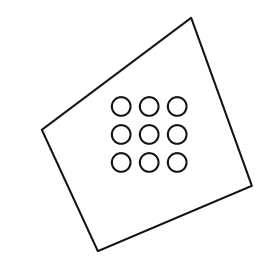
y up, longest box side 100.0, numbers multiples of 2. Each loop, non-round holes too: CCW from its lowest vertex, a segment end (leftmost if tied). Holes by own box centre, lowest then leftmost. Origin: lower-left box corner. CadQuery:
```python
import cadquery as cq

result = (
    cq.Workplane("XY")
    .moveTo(24.0, 0.0)
    .lineTo(90.0, 28.0)
    .lineTo(64.0, 100.0)
    .lineTo(0.0, 52.0)
    .close()
    .moveTo(34.0, 38.0)
    .circle(4.0)
    .moveTo(46.0, 38.0)
    .circle(4.0)
    .moveTo(58.0, 38.0)
    .circle(4.0)
    .moveTo(34.0, 50.0)
    .circle(4.0)
    .moveTo(46.0, 50.0)
    .circle(4.0)
    .moveTo(58.0, 50.0)
    .circle(4.0)
    .moveTo(34.0, 62.0)
    .circle(4.0)
    .moveTo(46.0, 62.0)
    .circle(4.0)
    .moveTo(58.0, 62.0)
    .circle(4.0)
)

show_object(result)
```